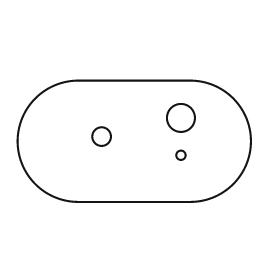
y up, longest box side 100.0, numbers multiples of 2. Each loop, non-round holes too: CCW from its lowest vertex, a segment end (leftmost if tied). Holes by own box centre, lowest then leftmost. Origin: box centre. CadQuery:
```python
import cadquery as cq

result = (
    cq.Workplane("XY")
    .moveTo(-24.0, -26.0)
    .lineTo(24.0, -26.0)
    .threePointArc((50.0, 0.0), (24.0, 26.0))
    .lineTo(-24.0, 26.0)
    .threePointArc((-50.0, 0.0), (-24.0, -26.0))
    .close()
    .moveTo(20.0, -6.0)
    .circle(2.0)
    .moveTo(-14.0, 2.0)
    .circle(4.0)
    .moveTo(20.0, 10.0)
    .circle(6.0)
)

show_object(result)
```